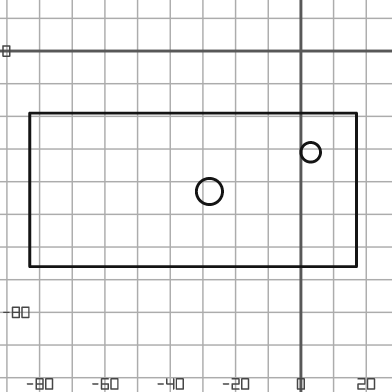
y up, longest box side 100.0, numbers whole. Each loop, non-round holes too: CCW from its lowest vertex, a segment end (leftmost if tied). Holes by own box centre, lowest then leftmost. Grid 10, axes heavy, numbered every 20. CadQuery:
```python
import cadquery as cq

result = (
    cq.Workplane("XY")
    .moveTo(-83.0, -66.0)
    .lineTo(17.0, -66.0)
    .lineTo(17.0, -19.0)
    .lineTo(-83.0, -19.0)
    .close()
    .moveTo(-28.0, -43.0)
    .circle(4.0)
    .moveTo(3.0, -31.0)
    .circle(3.0)
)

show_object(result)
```